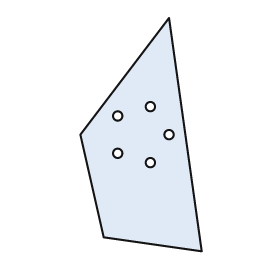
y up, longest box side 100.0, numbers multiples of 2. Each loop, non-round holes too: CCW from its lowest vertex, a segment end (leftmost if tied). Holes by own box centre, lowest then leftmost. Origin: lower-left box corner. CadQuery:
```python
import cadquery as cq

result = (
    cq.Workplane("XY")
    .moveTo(52.0, 0.0)
    .lineTo(38.0, 100.0)
    .lineTo(0.0, 50.0)
    .lineTo(10.0, 6.0)
    .close()
    .moveTo(30.0, 38.0)
    .circle(2.0)
    .moveTo(16.0, 42.0)
    .circle(2.0)
    .moveTo(38.0, 50.0)
    .circle(2.0)
    .moveTo(16.0, 58.0)
    .circle(2.0)
    .moveTo(30.0, 62.0)
    .circle(2.0)
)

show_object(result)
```